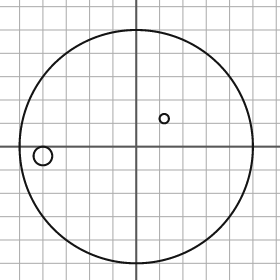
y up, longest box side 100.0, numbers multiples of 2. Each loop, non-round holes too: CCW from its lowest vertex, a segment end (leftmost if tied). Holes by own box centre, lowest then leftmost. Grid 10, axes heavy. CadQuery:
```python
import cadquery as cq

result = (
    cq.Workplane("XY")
    .moveTo(0.0, 0.0)
    .circle(50.0)
    .moveTo(-40.0, -4.0)
    .circle(4.0)
    .moveTo(12.0, 12.0)
    .circle(2.0)
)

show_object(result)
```